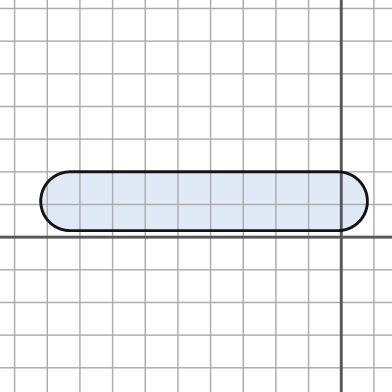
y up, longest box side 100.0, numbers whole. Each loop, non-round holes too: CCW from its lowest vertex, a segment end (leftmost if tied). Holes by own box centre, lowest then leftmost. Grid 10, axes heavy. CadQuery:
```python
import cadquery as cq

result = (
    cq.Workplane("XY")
    .moveTo(-83.0, 2.0)
    .lineTo(-1.0, 2.0)
    .threePointArc((8.0, 11.0), (-1.0, 20.0))
    .lineTo(-83.0, 20.0)
    .threePointArc((-92.0, 11.0), (-83.0, 2.0))
    .close()
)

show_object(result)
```